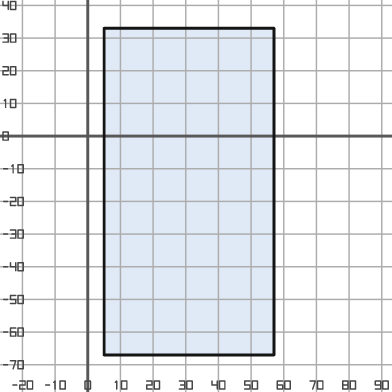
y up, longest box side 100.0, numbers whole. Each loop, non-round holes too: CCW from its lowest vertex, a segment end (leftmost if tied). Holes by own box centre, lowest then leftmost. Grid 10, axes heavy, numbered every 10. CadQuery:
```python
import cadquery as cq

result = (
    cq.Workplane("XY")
    .moveTo(5.0, -67.0)
    .lineTo(57.0, -67.0)
    .lineTo(57.0, 33.0)
    .lineTo(5.0, 33.0)
    .close()
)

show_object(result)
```